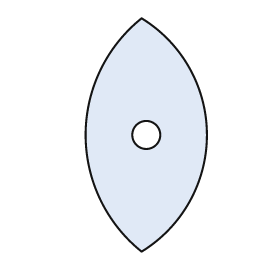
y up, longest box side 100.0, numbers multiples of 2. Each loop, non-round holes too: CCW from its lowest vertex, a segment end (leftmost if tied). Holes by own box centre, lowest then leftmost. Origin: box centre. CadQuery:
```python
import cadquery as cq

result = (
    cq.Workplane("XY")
    .moveTo(-2.0, -50.0)
    .threePointArc((26.0, 0.0), (-2.0, 50.0))
    .threePointArc((-26.0, 0.0), (-2.0, -50.0))
    .close()
    .moveTo(0.0, 0.0)
    .circle(6.0)
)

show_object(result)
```